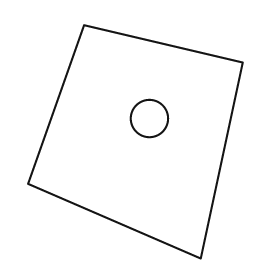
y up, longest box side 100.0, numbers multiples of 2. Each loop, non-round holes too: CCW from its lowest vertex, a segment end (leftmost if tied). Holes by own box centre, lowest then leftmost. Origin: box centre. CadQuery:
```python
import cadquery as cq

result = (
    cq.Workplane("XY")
    .moveTo(28.0, -50.0)
    .lineTo(46.0, 34.0)
    .lineTo(-22.0, 50.0)
    .lineTo(-46.0, -18.0)
    .close()
    .moveTo(6.0, 10.0)
    .circle(8.0)
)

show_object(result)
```